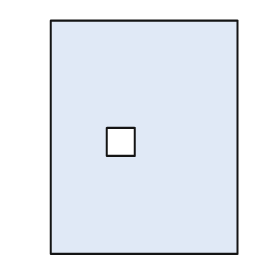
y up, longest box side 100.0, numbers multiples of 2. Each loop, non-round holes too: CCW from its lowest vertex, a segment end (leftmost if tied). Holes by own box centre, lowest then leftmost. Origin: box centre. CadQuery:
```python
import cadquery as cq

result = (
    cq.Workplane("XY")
    .moveTo(-40.0, -50.0)
    .lineTo(40.0, -50.0)
    .lineTo(40.0, 50.0)
    .lineTo(-40.0, 50.0)
    .close()
    .moveTo(-16.0, -8.0)
    .lineTo(-4.0, -8.0)
    .lineTo(-4.0, 4.0)
    .lineTo(-16.0, 4.0)
    .close()
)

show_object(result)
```